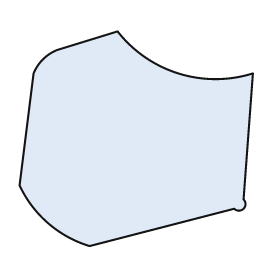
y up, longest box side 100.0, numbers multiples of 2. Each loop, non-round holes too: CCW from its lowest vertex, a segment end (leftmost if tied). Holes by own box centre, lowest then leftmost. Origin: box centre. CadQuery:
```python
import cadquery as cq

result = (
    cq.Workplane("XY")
    .moveTo(-20.0, -46.0)
    .lineTo(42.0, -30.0)
    .threePointArc((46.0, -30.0), (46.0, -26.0))
    .lineTo(50.0, 28.0)
    .threePointArc((18.0, 28.0), (-8.0, 46.0))
    .lineTo(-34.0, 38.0)
    .threePointArc((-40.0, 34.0), (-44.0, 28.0))
    .lineTo(-50.0, -20.0)
    .threePointArc((-38.0, -36.0), (-20.0, -46.0))
    .close()
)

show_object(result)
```